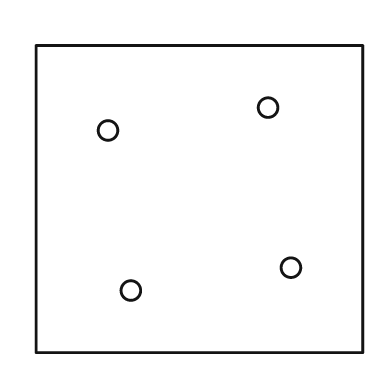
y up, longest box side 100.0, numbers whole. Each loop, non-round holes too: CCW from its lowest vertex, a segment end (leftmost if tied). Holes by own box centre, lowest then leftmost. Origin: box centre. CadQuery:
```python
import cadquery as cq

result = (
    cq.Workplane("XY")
    .moveTo(-50.0, -47.0)
    .lineTo(50.0, -47.0)
    .lineTo(50.0, 47.0)
    .lineTo(-50.0, 47.0)
    .close()
    .moveTo(-21.0, -28.0)
    .circle(3.0)
    .moveTo(28.0, -21.0)
    .circle(3.0)
    .moveTo(-28.0, 21.0)
    .circle(3.0)
    .moveTo(21.0, 28.0)
    .circle(3.0)
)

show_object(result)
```